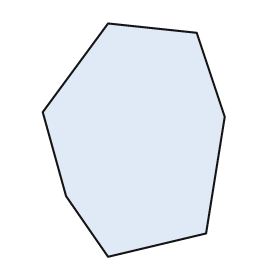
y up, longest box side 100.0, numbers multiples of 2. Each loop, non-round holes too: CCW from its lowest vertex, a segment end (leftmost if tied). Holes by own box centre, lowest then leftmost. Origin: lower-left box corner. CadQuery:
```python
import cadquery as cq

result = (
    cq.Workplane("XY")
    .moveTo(28.0, 0.0)
    .lineTo(70.0, 10.0)
    .lineTo(78.0, 60.0)
    .lineTo(66.0, 96.0)
    .lineTo(28.0, 100.0)
    .lineTo(0.0, 62.0)
    .lineTo(10.0, 26.0)
    .close()
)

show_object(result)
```